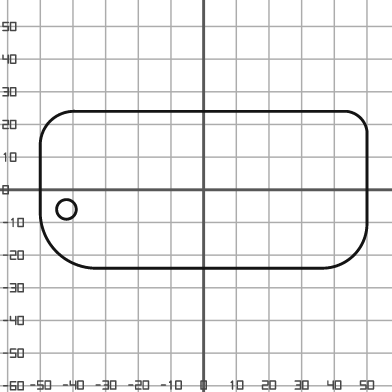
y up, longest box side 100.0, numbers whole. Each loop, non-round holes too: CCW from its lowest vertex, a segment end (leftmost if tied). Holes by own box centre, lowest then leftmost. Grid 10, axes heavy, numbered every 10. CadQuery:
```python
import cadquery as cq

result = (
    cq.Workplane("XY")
    .moveTo(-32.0, -24.0)
    .lineTo(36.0, -24.0)
    .threePointArc((46.0, -20.0), (50.0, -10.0))
    .lineTo(50.0, 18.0)
    .threePointArc((48.0, 22.0), (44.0, 24.0))
    .lineTo(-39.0, 24.0)
    .threePointArc((-47.0, 21.0), (-50.0, 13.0))
    .lineTo(-50.0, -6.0)
    .threePointArc((-45.0, -19.0), (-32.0, -24.0))
    .close()
    .moveTo(-42.0, -6.0)
    .circle(3.0)
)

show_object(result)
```